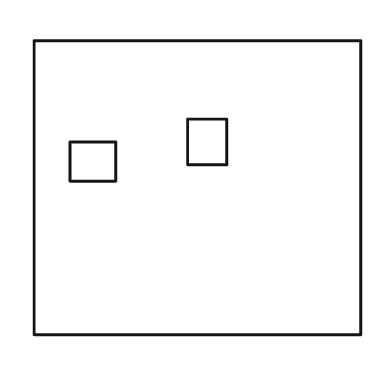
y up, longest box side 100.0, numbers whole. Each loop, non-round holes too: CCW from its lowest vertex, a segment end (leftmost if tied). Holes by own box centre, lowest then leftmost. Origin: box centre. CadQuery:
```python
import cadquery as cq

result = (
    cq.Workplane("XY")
    .moveTo(-50.0, -45.0)
    .lineTo(50.0, -45.0)
    .lineTo(50.0, 45.0)
    .lineTo(-50.0, 45.0)
    .close()
    .moveTo(-39.0, 2.0)
    .lineTo(-25.0, 2.0)
    .lineTo(-25.0, 14.0)
    .lineTo(-39.0, 14.0)
    .close()
    .moveTo(-3.0, 7.0)
    .lineTo(9.0, 7.0)
    .lineTo(9.0, 21.0)
    .lineTo(-3.0, 21.0)
    .close()
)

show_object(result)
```